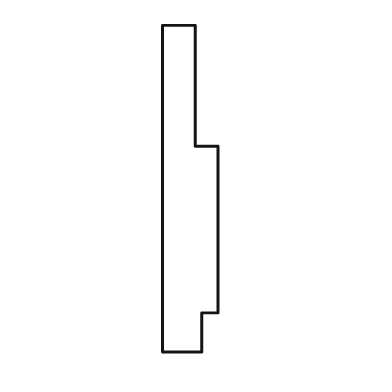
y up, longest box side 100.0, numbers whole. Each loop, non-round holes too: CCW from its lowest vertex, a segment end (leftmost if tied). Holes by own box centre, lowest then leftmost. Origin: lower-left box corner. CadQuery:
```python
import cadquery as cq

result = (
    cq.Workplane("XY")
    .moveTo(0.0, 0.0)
    .lineTo(12.0, 0.0)
    .lineTo(12.0, 12.0)
    .lineTo(17.0, 12.0)
    .lineTo(17.0, 63.0)
    .lineTo(10.0, 63.0)
    .lineTo(10.0, 100.0)
    .lineTo(0.0, 100.0)
    .close()
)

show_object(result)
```